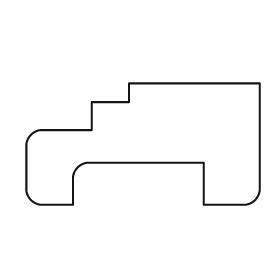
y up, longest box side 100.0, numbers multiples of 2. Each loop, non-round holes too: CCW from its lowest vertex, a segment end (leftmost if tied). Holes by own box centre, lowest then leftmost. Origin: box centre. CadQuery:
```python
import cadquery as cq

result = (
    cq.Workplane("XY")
    .moveTo(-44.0, -26.0)
    .lineTo(-30.0, -26.0)
    .lineTo(-30.0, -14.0)
    .threePointArc((-28.0, -10.0), (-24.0, -8.0))
    .lineTo(26.0, -8.0)
    .lineTo(26.0, -26.0)
    .lineTo(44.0, -26.0)
    .threePointArc((48.0, -24.0), (50.0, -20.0))
    .lineTo(50.0, 26.0)
    .lineTo(-6.0, 26.0)
    .lineTo(-6.0, 18.0)
    .lineTo(-22.0, 18.0)
    .lineTo(-22.0, 6.0)
    .lineTo(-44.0, 6.0)
    .threePointArc((-48.0, 4.0), (-50.0, 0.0))
    .lineTo(-50.0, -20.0)
    .threePointArc((-48.0, -24.0), (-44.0, -26.0))
    .close()
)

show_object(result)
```